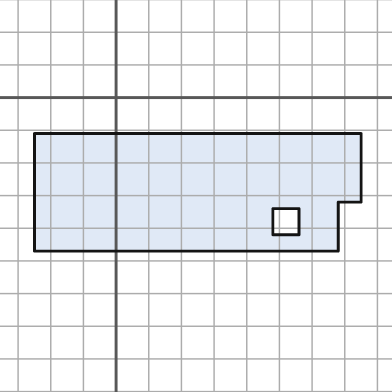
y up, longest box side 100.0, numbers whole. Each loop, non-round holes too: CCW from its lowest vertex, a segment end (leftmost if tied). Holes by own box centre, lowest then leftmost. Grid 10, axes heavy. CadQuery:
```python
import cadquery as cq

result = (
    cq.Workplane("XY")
    .moveTo(-25.0, -47.0)
    .lineTo(68.0, -47.0)
    .lineTo(68.0, -32.0)
    .lineTo(75.0, -32.0)
    .lineTo(75.0, -11.0)
    .lineTo(-25.0, -11.0)
    .close()
    .moveTo(48.0, -42.0)
    .lineTo(56.0, -42.0)
    .lineTo(56.0, -34.0)
    .lineTo(48.0, -34.0)
    .close()
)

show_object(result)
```